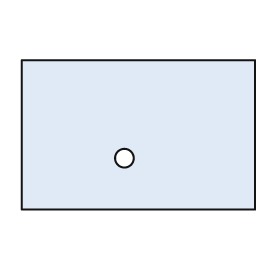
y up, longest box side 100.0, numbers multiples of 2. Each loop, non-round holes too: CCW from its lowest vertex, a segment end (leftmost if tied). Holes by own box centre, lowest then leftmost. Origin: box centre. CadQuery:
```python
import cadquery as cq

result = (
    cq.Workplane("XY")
    .moveTo(-50.0, -32.0)
    .lineTo(50.0, -32.0)
    .lineTo(50.0, 32.0)
    .lineTo(-50.0, 32.0)
    .close()
    .moveTo(-6.0, -10.0)
    .circle(4.0)
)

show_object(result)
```